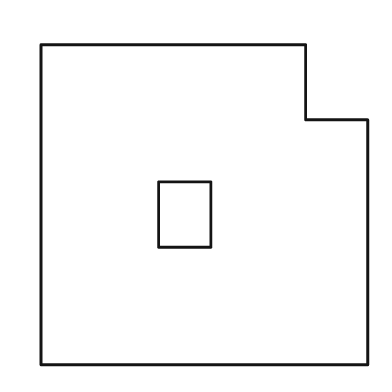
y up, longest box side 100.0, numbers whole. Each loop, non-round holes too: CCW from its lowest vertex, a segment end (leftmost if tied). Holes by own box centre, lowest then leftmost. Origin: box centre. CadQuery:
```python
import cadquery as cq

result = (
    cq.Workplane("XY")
    .moveTo(-50.0, -49.0)
    .lineTo(50.0, -49.0)
    .lineTo(50.0, 26.0)
    .lineTo(31.0, 26.0)
    .lineTo(31.0, 49.0)
    .lineTo(-50.0, 49.0)
    .close()
    .moveTo(-14.0, -13.0)
    .lineTo(2.0, -13.0)
    .lineTo(2.0, 7.0)
    .lineTo(-14.0, 7.0)
    .close()
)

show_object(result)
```